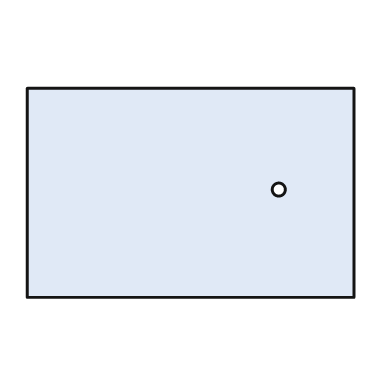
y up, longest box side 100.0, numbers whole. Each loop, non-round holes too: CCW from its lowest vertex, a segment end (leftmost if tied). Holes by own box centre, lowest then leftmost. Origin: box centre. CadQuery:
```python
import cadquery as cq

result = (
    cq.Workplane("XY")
    .moveTo(-50.0, -32.0)
    .lineTo(50.0, -32.0)
    .lineTo(50.0, 32.0)
    .lineTo(-50.0, 32.0)
    .close()
    .moveTo(27.0, 1.0)
    .circle(2.0)
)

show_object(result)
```